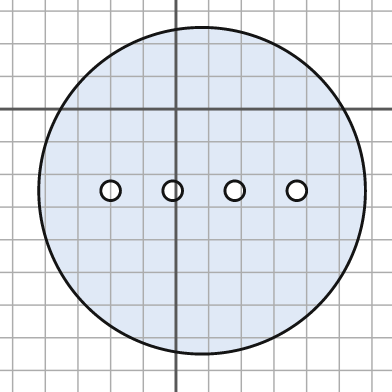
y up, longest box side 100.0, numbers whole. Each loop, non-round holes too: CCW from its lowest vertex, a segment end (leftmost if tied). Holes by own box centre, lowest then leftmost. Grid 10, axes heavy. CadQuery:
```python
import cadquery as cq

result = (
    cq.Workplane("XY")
    .moveTo(8.0, -25.0)
    .circle(50.0)
    .moveTo(-20.0, -25.0)
    .circle(3.0)
    .moveTo(-1.0, -25.0)
    .circle(3.0)
    .moveTo(18.0, -25.0)
    .circle(3.0)
    .moveTo(37.0, -25.0)
    .circle(3.0)
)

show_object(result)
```